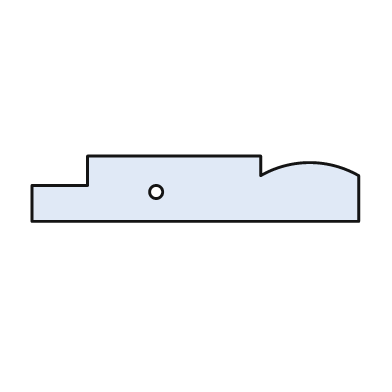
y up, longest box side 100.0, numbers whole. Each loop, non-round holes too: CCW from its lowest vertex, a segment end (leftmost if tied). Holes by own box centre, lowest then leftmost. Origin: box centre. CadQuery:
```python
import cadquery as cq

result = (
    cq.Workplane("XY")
    .moveTo(-50.0, -10.0)
    .lineTo(50.0, -10.0)
    .lineTo(50.0, 4.0)
    .threePointArc((35.0, 8.0), (20.0, 4.0))
    .lineTo(20.0, 10.0)
    .lineTo(-33.0, 10.0)
    .lineTo(-33.0, 1.0)
    .lineTo(-50.0, 1.0)
    .close()
    .moveTo(-12.0, -1.0)
    .circle(2.0)
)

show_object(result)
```